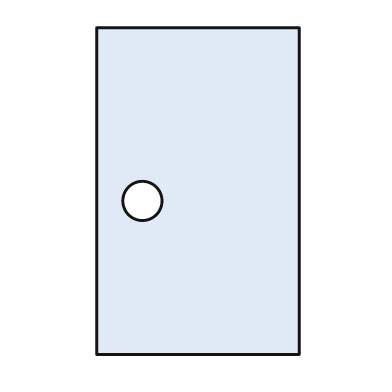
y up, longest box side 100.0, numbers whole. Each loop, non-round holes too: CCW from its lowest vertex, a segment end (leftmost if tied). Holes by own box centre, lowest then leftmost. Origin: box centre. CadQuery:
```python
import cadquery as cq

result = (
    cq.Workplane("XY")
    .moveTo(-31.0, -50.0)
    .lineTo(31.0, -50.0)
    .lineTo(31.0, 50.0)
    .lineTo(-31.0, 50.0)
    .close()
    .moveTo(-17.0, -3.0)
    .circle(6.0)
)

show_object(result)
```